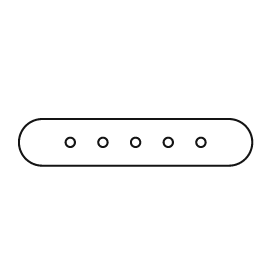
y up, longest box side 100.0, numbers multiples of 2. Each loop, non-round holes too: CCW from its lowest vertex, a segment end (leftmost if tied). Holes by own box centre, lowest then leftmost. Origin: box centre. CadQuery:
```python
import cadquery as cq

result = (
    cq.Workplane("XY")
    .moveTo(-40.0, -10.0)
    .lineTo(40.0, -10.0)
    .threePointArc((50.0, 0.0), (40.0, 10.0))
    .lineTo(-40.0, 10.0)
    .threePointArc((-50.0, 0.0), (-40.0, -10.0))
    .close()
    .moveTo(-28.0, 0.0)
    .circle(2.0)
    .moveTo(-14.0, 0.0)
    .circle(2.0)
    .moveTo(0.0, 0.0)
    .circle(2.0)
    .moveTo(14.0, 0.0)
    .circle(2.0)
    .moveTo(28.0, 0.0)
    .circle(2.0)
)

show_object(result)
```